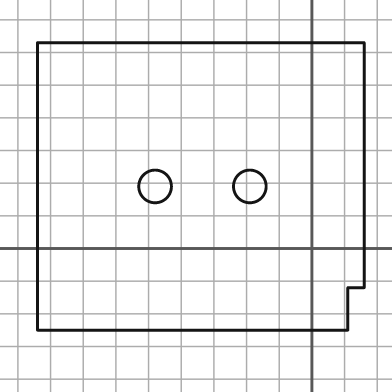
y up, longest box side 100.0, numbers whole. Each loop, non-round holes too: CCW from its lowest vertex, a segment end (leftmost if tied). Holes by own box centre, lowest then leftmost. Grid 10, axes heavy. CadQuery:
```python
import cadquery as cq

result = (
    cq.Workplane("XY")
    .moveTo(-84.0, -25.0)
    .lineTo(11.0, -25.0)
    .lineTo(11.0, -12.0)
    .lineTo(16.0, -12.0)
    .lineTo(16.0, 63.0)
    .lineTo(-84.0, 63.0)
    .close()
    .moveTo(-48.0, 19.0)
    .circle(5.0)
    .moveTo(-19.0, 19.0)
    .circle(5.0)
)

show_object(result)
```